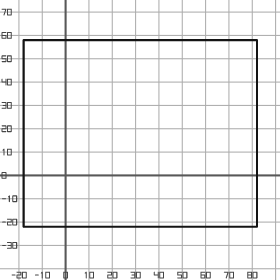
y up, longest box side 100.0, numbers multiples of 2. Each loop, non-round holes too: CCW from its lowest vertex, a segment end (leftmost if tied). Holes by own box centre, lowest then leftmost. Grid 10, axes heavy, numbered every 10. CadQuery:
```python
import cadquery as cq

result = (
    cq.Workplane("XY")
    .moveTo(-18.0, -22.0)
    .lineTo(82.0, -22.0)
    .lineTo(82.0, 58.0)
    .lineTo(-18.0, 58.0)
    .close()
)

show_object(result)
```